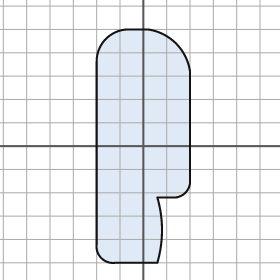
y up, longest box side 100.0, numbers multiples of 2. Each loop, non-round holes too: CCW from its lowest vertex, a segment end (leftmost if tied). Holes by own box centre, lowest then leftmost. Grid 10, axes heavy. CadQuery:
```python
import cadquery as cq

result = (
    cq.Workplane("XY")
    .moveTo(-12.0, -50.0)
    .lineTo(6.0, -50.0)
    .threePointArc((8.0, -36.0), (6.0, -22.0))
    .lineTo(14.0, -22.0)
    .threePointArc((18.0, -20.0), (20.0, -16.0))
    .lineTo(20.0, 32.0)
    .threePointArc((14.0, 44.0), (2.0, 50.0))
    .lineTo(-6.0, 50.0)
    .threePointArc((-16.0, 46.0), (-20.0, 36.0))
    .lineTo(-20.0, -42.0)
    .threePointArc((-18.0, -48.0), (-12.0, -50.0))
    .close()
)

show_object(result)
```